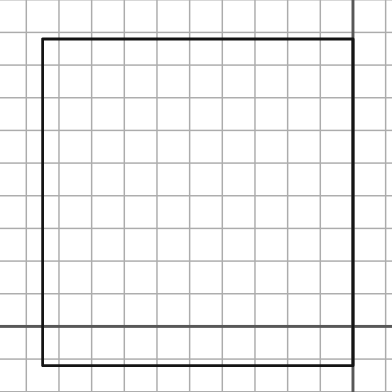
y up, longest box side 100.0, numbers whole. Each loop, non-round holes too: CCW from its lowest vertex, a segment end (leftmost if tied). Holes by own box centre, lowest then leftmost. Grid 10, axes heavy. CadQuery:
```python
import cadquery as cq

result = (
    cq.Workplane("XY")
    .moveTo(-95.0, -12.0)
    .lineTo(0.0, -12.0)
    .lineTo(0.0, 88.0)
    .lineTo(-95.0, 88.0)
    .close()
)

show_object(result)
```